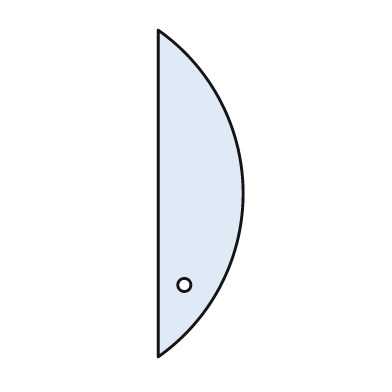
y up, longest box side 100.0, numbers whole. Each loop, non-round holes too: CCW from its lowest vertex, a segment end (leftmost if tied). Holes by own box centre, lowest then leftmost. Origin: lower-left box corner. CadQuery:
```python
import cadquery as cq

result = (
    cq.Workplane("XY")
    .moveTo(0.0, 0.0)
    .threePointArc((26.0, 50.0), (0.0, 100.0))
    .close()
    .moveTo(8.0, 22.0)
    .circle(2.0)
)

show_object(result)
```